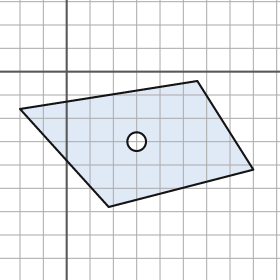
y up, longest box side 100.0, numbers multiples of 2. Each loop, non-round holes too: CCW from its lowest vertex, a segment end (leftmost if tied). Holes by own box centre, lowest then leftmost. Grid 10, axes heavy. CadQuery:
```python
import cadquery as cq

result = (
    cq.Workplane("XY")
    .moveTo(18.0, -58.0)
    .lineTo(80.0, -42.0)
    .lineTo(56.0, -4.0)
    .lineTo(-20.0, -16.0)
    .close()
    .moveTo(30.0, -30.0)
    .circle(4.0)
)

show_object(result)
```